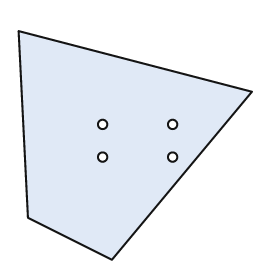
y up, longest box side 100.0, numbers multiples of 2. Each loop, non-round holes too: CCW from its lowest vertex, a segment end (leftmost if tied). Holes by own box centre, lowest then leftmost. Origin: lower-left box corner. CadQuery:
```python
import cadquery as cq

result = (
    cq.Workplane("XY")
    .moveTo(40.0, 0.0)
    .lineTo(100.0, 72.0)
    .lineTo(0.0, 98.0)
    .lineTo(4.0, 18.0)
    .close()
    .moveTo(36.0, 44.0)
    .circle(2.0)
    .moveTo(66.0, 44.0)
    .circle(2.0)
    .moveTo(36.0, 58.0)
    .circle(2.0)
    .moveTo(66.0, 58.0)
    .circle(2.0)
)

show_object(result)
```